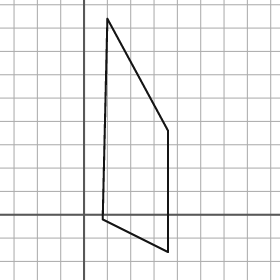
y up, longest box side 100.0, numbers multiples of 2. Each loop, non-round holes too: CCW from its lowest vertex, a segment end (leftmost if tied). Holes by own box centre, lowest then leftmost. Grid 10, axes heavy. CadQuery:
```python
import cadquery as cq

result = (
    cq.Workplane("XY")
    .moveTo(36.0, -16.0)
    .lineTo(36.0, 36.0)
    .lineTo(10.0, 84.0)
    .lineTo(8.0, -2.0)
    .close()
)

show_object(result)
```